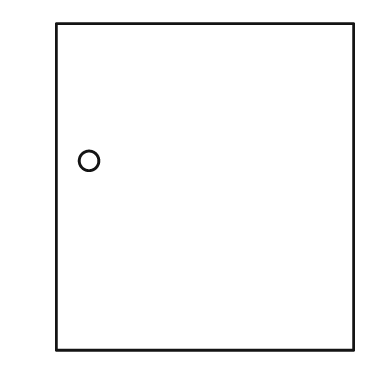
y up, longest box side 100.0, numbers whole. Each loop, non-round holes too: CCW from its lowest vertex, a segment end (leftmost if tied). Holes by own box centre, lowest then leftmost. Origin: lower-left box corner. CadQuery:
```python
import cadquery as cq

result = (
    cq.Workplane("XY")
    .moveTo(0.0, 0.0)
    .lineTo(91.0, 0.0)
    .lineTo(91.0, 100.0)
    .lineTo(0.0, 100.0)
    .close()
    .moveTo(10.0, 58.0)
    .circle(3.0)
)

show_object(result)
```